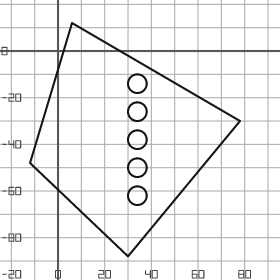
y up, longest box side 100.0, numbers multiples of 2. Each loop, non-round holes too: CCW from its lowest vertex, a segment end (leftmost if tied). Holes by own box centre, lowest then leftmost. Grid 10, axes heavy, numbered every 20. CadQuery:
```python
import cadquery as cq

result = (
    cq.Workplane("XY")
    .moveTo(30.0, -88.0)
    .lineTo(78.0, -30.0)
    .lineTo(6.0, 12.0)
    .lineTo(-12.0, -48.0)
    .close()
    .moveTo(34.0, -62.0)
    .circle(4.0)
    .moveTo(34.0, -50.0)
    .circle(4.0)
    .moveTo(34.0, -38.0)
    .circle(4.0)
    .moveTo(34.0, -26.0)
    .circle(4.0)
    .moveTo(34.0, -14.0)
    .circle(4.0)
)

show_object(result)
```